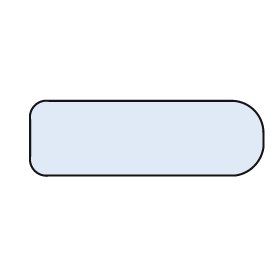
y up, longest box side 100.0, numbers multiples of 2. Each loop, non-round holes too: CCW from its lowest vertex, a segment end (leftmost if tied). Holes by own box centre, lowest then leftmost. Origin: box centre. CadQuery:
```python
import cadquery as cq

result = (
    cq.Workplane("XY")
    .moveTo(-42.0, -16.0)
    .lineTo(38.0, -16.0)
    .threePointArc((46.0, -12.0), (50.0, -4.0))
    .lineTo(50.0, 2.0)
    .threePointArc((46.0, 12.0), (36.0, 16.0))
    .lineTo(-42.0, 16.0)
    .threePointArc((-48.0, 14.0), (-50.0, 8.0))
    .lineTo(-50.0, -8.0)
    .threePointArc((-48.0, -14.0), (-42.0, -16.0))
    .close()
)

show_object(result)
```